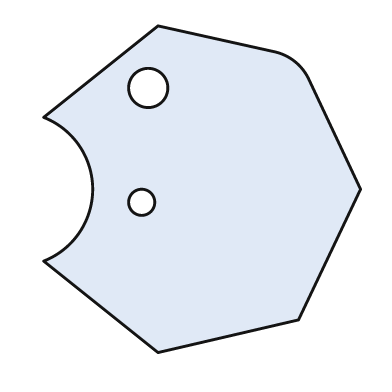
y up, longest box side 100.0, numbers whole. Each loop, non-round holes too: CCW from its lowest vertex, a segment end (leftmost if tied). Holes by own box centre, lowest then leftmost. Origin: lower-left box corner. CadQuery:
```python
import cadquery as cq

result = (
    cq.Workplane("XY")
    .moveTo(35.0, 0.0)
    .lineTo(78.0, 10.0)
    .lineTo(97.0, 50.0)
    .lineTo(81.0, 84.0)
    .threePointArc((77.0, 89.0), (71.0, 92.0))
    .lineTo(35.0, 100.0)
    .lineTo(0.0, 72.0)
    .threePointArc((15.0, 50.0), (0.0, 28.0))
    .close()
    .moveTo(30.0, 46.0)
    .circle(4.0)
    .moveTo(32.0, 81.0)
    .circle(6.0)
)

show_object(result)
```